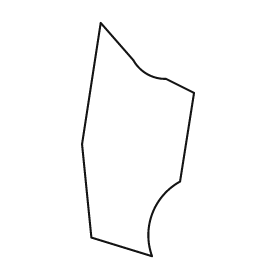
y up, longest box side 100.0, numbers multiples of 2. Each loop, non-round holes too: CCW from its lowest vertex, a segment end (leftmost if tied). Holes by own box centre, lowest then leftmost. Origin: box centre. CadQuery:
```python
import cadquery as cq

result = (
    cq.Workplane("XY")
    .moveTo(6.0, -50.0)
    .threePointArc((6.0, -32.0), (18.0, -18.0))
    .lineTo(24.0, 20.0)
    .lineTo(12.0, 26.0)
    .threePointArc((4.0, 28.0), (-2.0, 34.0))
    .lineTo(-16.0, 50.0)
    .lineTo(-24.0, -2.0)
    .lineTo(-20.0, -42.0)
    .close()
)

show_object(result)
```